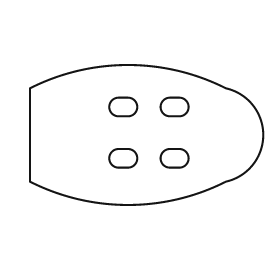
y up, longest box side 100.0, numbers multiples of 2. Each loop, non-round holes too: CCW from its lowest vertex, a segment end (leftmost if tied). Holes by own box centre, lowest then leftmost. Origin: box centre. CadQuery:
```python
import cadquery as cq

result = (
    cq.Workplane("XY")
    .moveTo(-50.0, -20.0)
    .threePointArc((-8.0, -30.0), (34.0, -20.0))
    .threePointArc((50.0, 0.0), (34.0, 20.0))
    .threePointArc((-8.0, 30.0), (-50.0, 20.0))
    .close()
    .moveTo(-12.0, -14.0)
    .lineTo(-8.0, -14.0)
    .threePointArc((-4.0, -10.0), (-8.0, -6.0))
    .lineTo(-12.0, -6.0)
    .threePointArc((-16.0, -10.0), (-12.0, -14.0))
    .close()
    .moveTo(10.0, -14.0)
    .lineTo(14.0, -14.0)
    .threePointArc((18.0, -10.0), (14.0, -6.0))
    .lineTo(10.0, -6.0)
    .threePointArc((6.0, -10.0), (10.0, -14.0))
    .close()
    .moveTo(-12.0, 8.0)
    .lineTo(-8.0, 8.0)
    .threePointArc((-4.0, 12.0), (-8.0, 16.0))
    .lineTo(-12.0, 16.0)
    .threePointArc((-16.0, 12.0), (-12.0, 8.0))
    .close()
    .moveTo(10.0, 8.0)
    .lineTo(14.0, 8.0)
    .threePointArc((18.0, 12.0), (14.0, 16.0))
    .lineTo(10.0, 16.0)
    .threePointArc((6.0, 12.0), (10.0, 8.0))
    .close()
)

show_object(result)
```